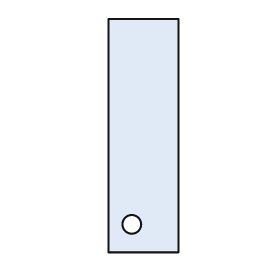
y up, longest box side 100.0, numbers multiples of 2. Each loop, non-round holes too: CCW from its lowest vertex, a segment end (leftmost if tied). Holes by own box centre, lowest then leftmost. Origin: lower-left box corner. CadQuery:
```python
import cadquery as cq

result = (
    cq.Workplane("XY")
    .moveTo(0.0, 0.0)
    .lineTo(30.0, 0.0)
    .lineTo(30.0, 100.0)
    .lineTo(0.0, 100.0)
    .close()
    .moveTo(10.0, 12.0)
    .circle(4.0)
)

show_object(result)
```